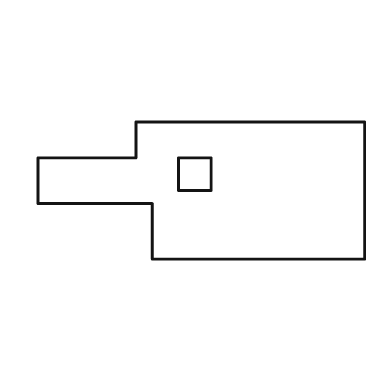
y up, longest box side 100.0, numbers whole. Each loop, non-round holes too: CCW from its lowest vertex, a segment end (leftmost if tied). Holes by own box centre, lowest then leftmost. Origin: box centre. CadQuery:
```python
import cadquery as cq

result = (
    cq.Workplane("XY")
    .moveTo(-15.0, -21.0)
    .lineTo(50.0, -21.0)
    .lineTo(50.0, 21.0)
    .lineTo(-20.0, 21.0)
    .lineTo(-20.0, 10.0)
    .lineTo(-50.0, 10.0)
    .lineTo(-50.0, -4.0)
    .lineTo(-15.0, -4.0)
    .close()
    .moveTo(-7.0, 0.0)
    .lineTo(3.0, 0.0)
    .lineTo(3.0, 10.0)
    .lineTo(-7.0, 10.0)
    .close()
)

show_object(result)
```